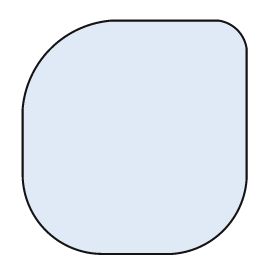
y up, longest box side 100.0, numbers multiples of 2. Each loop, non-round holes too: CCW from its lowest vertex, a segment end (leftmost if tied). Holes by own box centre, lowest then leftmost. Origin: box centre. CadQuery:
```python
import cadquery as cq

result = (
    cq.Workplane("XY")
    .moveTo(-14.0, -50.0)
    .lineTo(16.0, -50.0)
    .threePointArc((38.0, -40.0), (48.0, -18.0))
    .lineTo(48.0, 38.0)
    .threePointArc((44.0, 46.0), (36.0, 50.0))
    .lineTo(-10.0, 50.0)
    .threePointArc((-36.0, 38.0), (-48.0, 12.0))
    .lineTo(-48.0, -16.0)
    .threePointArc((-38.0, -40.0), (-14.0, -50.0))
    .close()
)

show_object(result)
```